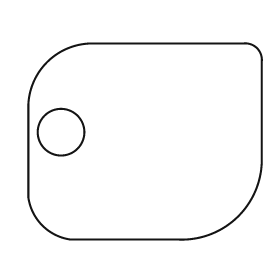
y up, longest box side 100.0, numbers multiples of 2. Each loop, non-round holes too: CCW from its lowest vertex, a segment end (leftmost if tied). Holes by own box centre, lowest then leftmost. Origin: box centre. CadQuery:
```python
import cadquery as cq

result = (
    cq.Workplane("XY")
    .moveTo(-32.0, -42.0)
    .lineTo(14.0, -42.0)
    .threePointArc((40.0, -32.0), (50.0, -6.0))
    .lineTo(50.0, 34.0)
    .threePointArc((48.0, 40.0), (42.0, 42.0))
    .lineTo(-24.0, 42.0)
    .threePointArc((-42.0, 34.0), (-50.0, 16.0))
    .lineTo(-50.0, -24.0)
    .threePointArc((-44.0, -36.0), (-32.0, -42.0))
    .close()
    .moveTo(-36.0, 4.0)
    .circle(10.0)
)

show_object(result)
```